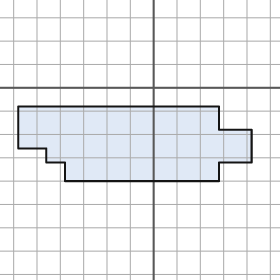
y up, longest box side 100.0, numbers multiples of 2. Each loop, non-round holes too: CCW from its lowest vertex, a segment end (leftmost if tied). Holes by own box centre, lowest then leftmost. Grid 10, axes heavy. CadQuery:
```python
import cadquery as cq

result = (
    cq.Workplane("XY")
    .moveTo(-38.0, -40.0)
    .lineTo(28.0, -40.0)
    .lineTo(28.0, -32.0)
    .lineTo(42.0, -32.0)
    .lineTo(42.0, -18.0)
    .lineTo(28.0, -18.0)
    .lineTo(28.0, -8.0)
    .lineTo(-58.0, -8.0)
    .lineTo(-58.0, -26.0)
    .lineTo(-46.0, -26.0)
    .lineTo(-46.0, -32.0)
    .lineTo(-38.0, -32.0)
    .close()
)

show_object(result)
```